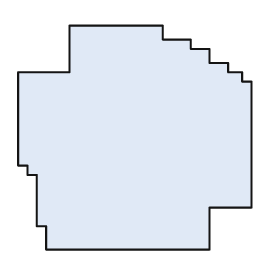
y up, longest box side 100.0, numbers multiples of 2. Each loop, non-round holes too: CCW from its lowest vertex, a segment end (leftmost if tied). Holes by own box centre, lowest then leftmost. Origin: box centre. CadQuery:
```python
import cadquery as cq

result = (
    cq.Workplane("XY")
    .moveTo(-38.0, -48.0)
    .lineTo(32.0, -48.0)
    .lineTo(32.0, -30.0)
    .lineTo(50.0, -30.0)
    .lineTo(50.0, 24.0)
    .lineTo(46.0, 24.0)
    .lineTo(46.0, 28.0)
    .lineTo(40.0, 28.0)
    .lineTo(40.0, 32.0)
    .lineTo(32.0, 32.0)
    .lineTo(32.0, 38.0)
    .lineTo(24.0, 38.0)
    .lineTo(24.0, 42.0)
    .lineTo(12.0, 42.0)
    .lineTo(12.0, 48.0)
    .lineTo(-28.0, 48.0)
    .lineTo(-28.0, 28.0)
    .lineTo(-50.0, 28.0)
    .lineTo(-50.0, -12.0)
    .lineTo(-46.0, -12.0)
    .lineTo(-46.0, -16.0)
    .lineTo(-42.0, -16.0)
    .lineTo(-42.0, -38.0)
    .lineTo(-38.0, -38.0)
    .close()
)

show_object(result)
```